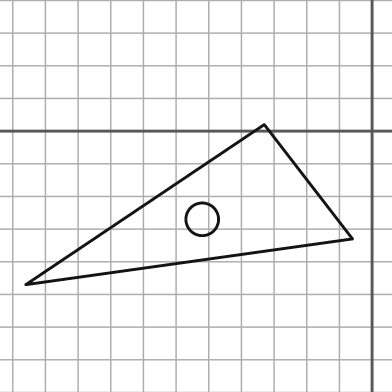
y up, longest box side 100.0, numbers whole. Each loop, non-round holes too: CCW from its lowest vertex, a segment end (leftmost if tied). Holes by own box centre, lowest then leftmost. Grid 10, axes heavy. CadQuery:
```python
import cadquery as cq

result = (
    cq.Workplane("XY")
    .moveTo(-106.0, -47.0)
    .lineTo(-6.0, -33.0)
    .lineTo(-33.0, 2.0)
    .close()
    .moveTo(-52.0, -27.0)
    .circle(5.0)
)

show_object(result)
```